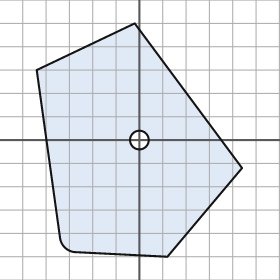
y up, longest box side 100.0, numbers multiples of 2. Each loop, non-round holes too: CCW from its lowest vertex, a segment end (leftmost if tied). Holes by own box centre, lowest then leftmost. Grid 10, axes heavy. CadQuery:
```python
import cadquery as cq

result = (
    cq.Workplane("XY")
    .moveTo(12.0, -50.0)
    .lineTo(44.0, -12.0)
    .lineTo(-2.0, 50.0)
    .lineTo(-44.0, 30.0)
    .lineTo(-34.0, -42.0)
    .threePointArc((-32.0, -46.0), (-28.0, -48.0))
    .close()
    .moveTo(0.0, 0.0)
    .circle(4.0)
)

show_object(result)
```